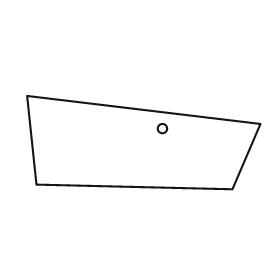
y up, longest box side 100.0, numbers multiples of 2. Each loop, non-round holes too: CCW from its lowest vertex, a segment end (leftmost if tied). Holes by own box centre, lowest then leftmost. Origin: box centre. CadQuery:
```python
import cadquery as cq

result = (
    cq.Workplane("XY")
    .moveTo(38.0, -20.0)
    .lineTo(50.0, 8.0)
    .lineTo(-50.0, 20.0)
    .lineTo(-46.0, -18.0)
    .close()
    .moveTo(8.0, 6.0)
    .circle(2.0)
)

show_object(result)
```